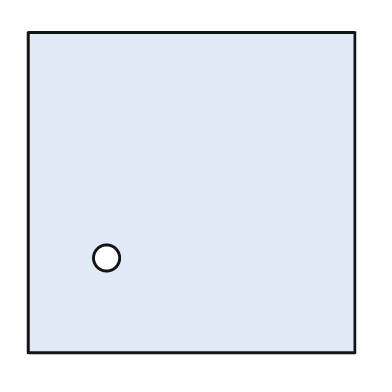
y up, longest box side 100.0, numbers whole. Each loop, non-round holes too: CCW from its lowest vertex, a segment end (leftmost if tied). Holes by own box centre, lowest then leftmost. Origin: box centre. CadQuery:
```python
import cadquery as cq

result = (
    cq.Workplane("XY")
    .moveTo(-50.0, -49.0)
    .lineTo(50.0, -49.0)
    .lineTo(50.0, 49.0)
    .lineTo(-50.0, 49.0)
    .close()
    .moveTo(-26.0, -20.0)
    .circle(4.0)
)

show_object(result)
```